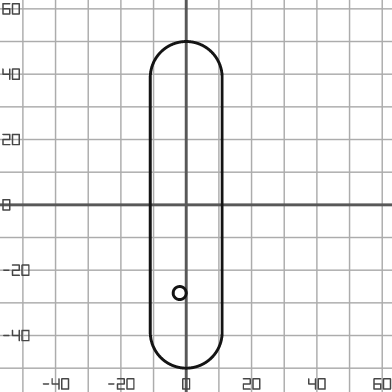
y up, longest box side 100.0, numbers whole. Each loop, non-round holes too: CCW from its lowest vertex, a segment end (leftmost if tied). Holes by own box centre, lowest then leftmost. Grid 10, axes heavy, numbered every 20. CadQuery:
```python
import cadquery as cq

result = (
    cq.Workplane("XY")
    .moveTo(-11.0, -39.0)
    .threePointArc((0.0, -50.0), (11.0, -39.0))
    .lineTo(11.0, 39.0)
    .threePointArc((0.0, 50.0), (-11.0, 39.0))
    .close()
    .moveTo(-2.0, -27.0)
    .circle(2.0)
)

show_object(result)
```